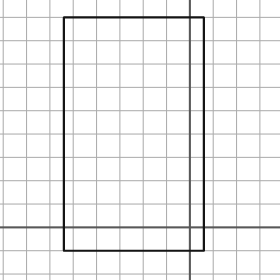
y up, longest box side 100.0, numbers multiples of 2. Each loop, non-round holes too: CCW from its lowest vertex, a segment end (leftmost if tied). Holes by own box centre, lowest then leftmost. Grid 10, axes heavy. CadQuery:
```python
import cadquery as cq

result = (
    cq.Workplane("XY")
    .moveTo(-54.0, -10.0)
    .lineTo(6.0, -10.0)
    .lineTo(6.0, 90.0)
    .lineTo(-54.0, 90.0)
    .close()
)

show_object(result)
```